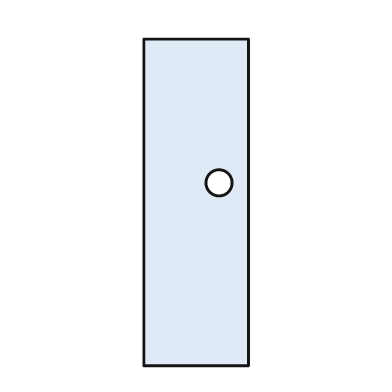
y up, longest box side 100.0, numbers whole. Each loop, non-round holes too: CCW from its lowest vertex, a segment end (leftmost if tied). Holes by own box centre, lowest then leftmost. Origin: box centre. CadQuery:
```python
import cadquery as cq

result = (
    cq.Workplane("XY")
    .moveTo(-16.0, -50.0)
    .lineTo(16.0, -50.0)
    .lineTo(16.0, 50.0)
    .lineTo(-16.0, 50.0)
    .close()
    .moveTo(7.0, 6.0)
    .circle(4.0)
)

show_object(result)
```